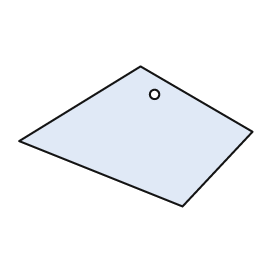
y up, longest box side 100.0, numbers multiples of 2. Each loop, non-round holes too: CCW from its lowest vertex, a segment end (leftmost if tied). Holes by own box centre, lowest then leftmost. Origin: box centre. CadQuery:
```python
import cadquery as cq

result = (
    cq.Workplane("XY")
    .moveTo(20.0, -30.0)
    .lineTo(50.0, 2.0)
    .lineTo(2.0, 30.0)
    .lineTo(-50.0, -2.0)
    .close()
    .moveTo(8.0, 18.0)
    .circle(2.0)
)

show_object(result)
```